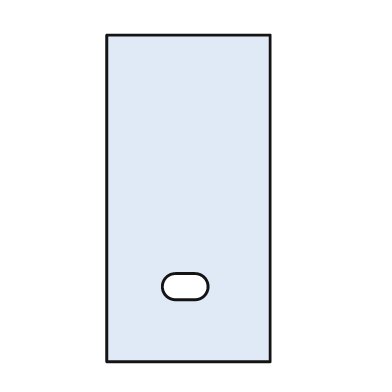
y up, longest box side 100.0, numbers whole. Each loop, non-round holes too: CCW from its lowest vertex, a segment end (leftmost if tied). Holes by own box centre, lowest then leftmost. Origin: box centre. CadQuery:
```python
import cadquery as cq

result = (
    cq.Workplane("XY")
    .moveTo(-25.0, -50.0)
    .lineTo(25.0, -50.0)
    .lineTo(25.0, 50.0)
    .lineTo(-25.0, 50.0)
    .close()
    .moveTo(-4.0, -31.0)
    .lineTo(2.0, -31.0)
    .threePointArc((6.0, -27.0), (2.0, -23.0))
    .lineTo(-4.0, -23.0)
    .threePointArc((-8.0, -27.0), (-4.0, -31.0))
    .close()
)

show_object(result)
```